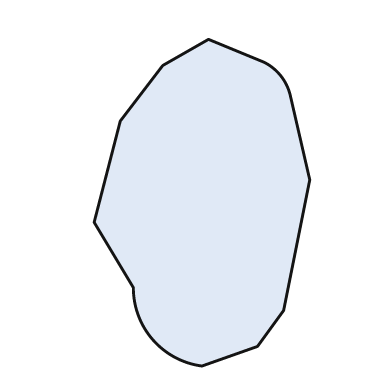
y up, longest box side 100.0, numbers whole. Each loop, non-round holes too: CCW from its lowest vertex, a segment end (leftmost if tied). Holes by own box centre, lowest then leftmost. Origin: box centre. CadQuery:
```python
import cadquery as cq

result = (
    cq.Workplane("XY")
    .moveTo(0.0, -50.0)
    .lineTo(17.0, -44.0)
    .lineTo(25.0, -33.0)
    .lineTo(33.0, 7.0)
    .lineTo(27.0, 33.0)
    .threePointArc((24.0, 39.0), (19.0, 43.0))
    .lineTo(2.0, 50.0)
    .lineTo(-12.0, 42.0)
    .lineTo(-25.0, 25.0)
    .lineTo(-33.0, -6.0)
    .lineTo(-21.0, -26.0)
    .threePointArc((-15.0, -42.0), (0.0, -50.0))
    .close()
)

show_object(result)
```